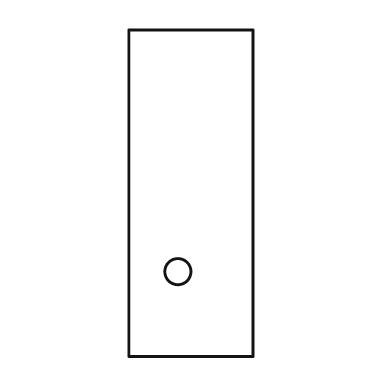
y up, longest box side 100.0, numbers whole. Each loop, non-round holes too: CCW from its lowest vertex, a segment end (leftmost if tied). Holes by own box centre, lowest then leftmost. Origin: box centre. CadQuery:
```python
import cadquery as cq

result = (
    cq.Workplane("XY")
    .moveTo(-19.0, -50.0)
    .lineTo(19.0, -50.0)
    .lineTo(19.0, 50.0)
    .lineTo(-19.0, 50.0)
    .close()
    .moveTo(-4.0, -24.0)
    .circle(4.0)
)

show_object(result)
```